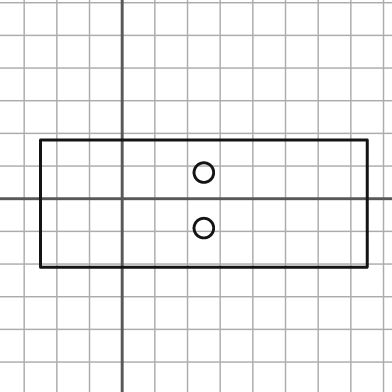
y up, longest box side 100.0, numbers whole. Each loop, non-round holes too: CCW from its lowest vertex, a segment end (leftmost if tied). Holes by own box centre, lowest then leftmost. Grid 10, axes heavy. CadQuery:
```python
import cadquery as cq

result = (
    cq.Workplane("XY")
    .moveTo(-25.0, -21.0)
    .lineTo(75.0, -21.0)
    .lineTo(75.0, 18.0)
    .lineTo(-25.0, 18.0)
    .close()
    .moveTo(25.0, -9.0)
    .circle(3.0)
    .moveTo(25.0, 8.0)
    .circle(3.0)
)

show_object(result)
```